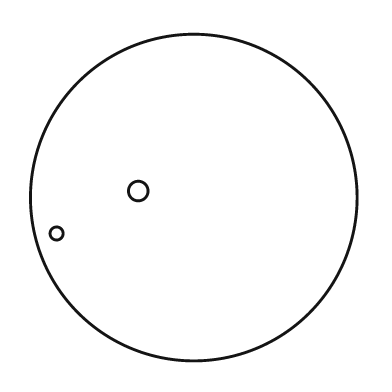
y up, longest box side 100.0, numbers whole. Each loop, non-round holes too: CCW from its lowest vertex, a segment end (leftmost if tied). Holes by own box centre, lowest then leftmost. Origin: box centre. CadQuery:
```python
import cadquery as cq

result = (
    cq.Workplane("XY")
    .moveTo(0.0, 0.0)
    .circle(50.0)
    .moveTo(-42.0, -11.0)
    .circle(2.0)
    .moveTo(-17.0, 2.0)
    .circle(3.0)
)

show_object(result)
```